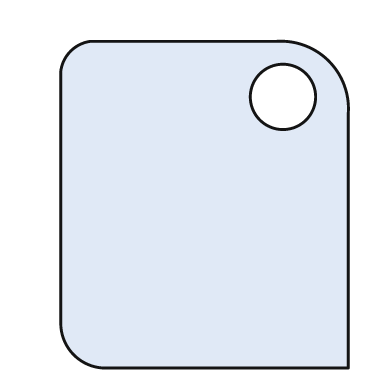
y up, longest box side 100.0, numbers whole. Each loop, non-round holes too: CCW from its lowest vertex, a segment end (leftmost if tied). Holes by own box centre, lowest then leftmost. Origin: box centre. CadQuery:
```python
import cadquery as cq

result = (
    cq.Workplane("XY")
    .moveTo(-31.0, -50.0)
    .lineTo(44.0, -50.0)
    .lineTo(44.0, 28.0)
    .threePointArc((38.0, 44.0), (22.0, 50.0))
    .lineTo(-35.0, 50.0)
    .threePointArc((-41.0, 47.0), (-44.0, 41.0))
    .lineTo(-44.0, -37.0)
    .threePointArc((-40.0, -46.0), (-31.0, -50.0))
    .close()
    .moveTo(24.0, 33.0)
    .circle(10.0)
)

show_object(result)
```